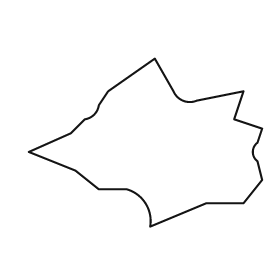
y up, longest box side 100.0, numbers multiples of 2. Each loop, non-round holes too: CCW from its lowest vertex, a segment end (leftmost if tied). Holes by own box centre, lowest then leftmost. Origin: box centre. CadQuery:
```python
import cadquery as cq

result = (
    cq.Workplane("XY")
    .moveTo(2.0, -36.0)
    .lineTo(26.0, -26.0)
    .lineTo(42.0, -26.0)
    .lineTo(50.0, -16.0)
    .lineTo(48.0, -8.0)
    .threePointArc((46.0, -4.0), (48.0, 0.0))
    .lineTo(50.0, 6.0)
    .lineTo(38.0, 10.0)
    .lineTo(42.0, 22.0)
    .lineTo(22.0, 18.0)
    .threePointArc((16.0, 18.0), (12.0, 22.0))
    .lineTo(4.0, 36.0)
    .lineTo(-16.0, 22.0)
    .lineTo(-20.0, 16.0)
    .threePointArc((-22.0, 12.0), (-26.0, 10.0))
    .lineTo(-32.0, 4.0)
    .lineTo(-50.0, -4.0)
    .lineTo(-30.0, -12.0)
    .lineTo(-20.0, -20.0)
    .lineTo(-8.0, -20.0)
    .threePointArc((0.0, -26.0), (2.0, -36.0))
    .close()
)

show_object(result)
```